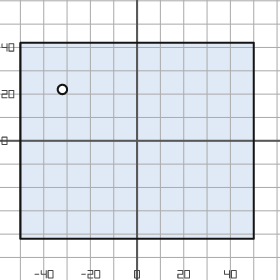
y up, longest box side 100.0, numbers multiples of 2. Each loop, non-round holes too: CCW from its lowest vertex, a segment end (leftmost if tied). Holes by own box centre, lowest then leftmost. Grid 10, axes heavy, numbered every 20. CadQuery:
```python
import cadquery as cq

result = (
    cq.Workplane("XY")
    .moveTo(-50.0, -42.0)
    .lineTo(50.0, -42.0)
    .lineTo(50.0, 42.0)
    .lineTo(-50.0, 42.0)
    .close()
    .moveTo(-32.0, 22.0)
    .circle(2.0)
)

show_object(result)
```